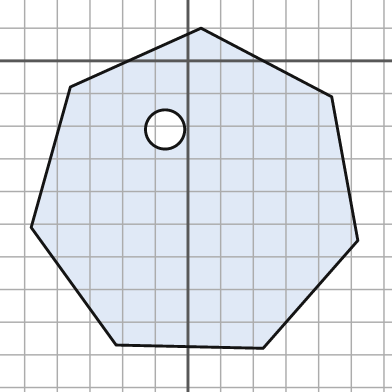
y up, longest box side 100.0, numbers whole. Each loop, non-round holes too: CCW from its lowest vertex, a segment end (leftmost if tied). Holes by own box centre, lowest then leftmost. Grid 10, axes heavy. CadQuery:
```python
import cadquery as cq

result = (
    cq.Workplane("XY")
    .moveTo(23.0, -88.0)
    .lineTo(52.0, -55.0)
    .lineTo(44.0, -11.0)
    .lineTo(4.0, 10.0)
    .lineTo(-36.0, -8.0)
    .lineTo(-48.0, -51.0)
    .lineTo(-22.0, -87.0)
    .close()
    .moveTo(-7.0, -21.0)
    .circle(6.0)
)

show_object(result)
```